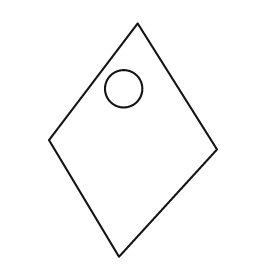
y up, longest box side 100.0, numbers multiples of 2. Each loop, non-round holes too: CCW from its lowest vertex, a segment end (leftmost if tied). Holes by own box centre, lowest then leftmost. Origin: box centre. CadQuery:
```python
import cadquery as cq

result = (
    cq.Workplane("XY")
    .moveTo(-6.0, -50.0)
    .lineTo(36.0, -4.0)
    .lineTo(2.0, 50.0)
    .lineTo(-36.0, 0.0)
    .close()
    .moveTo(-4.0, 22.0)
    .circle(8.0)
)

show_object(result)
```